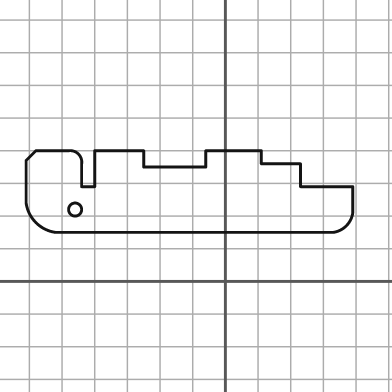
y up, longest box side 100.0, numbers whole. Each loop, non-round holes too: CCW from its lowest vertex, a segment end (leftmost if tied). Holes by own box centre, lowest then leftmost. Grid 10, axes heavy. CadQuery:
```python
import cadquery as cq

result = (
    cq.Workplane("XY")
    .moveTo(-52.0, 15.0)
    .lineTo(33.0, 15.0)
    .threePointArc((37.0, 17.0), (39.0, 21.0))
    .lineTo(39.0, 29.0)
    .lineTo(23.0, 29.0)
    .lineTo(23.0, 36.0)
    .lineTo(11.0, 36.0)
    .lineTo(11.0, 40.0)
    .lineTo(-6.0, 40.0)
    .lineTo(-6.0, 35.0)
    .lineTo(-25.0, 35.0)
    .lineTo(-25.0, 40.0)
    .lineTo(-40.0, 40.0)
    .lineTo(-40.0, 29.0)
    .lineTo(-44.0, 29.0)
    .lineTo(-44.0, 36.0)
    .threePointArc((-45.0, 39.0), (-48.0, 40.0))
    .lineTo(-58.0, 40.0)
    .lineTo(-61.0, 37.0)
    .lineTo(-61.0, 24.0)
    .threePointArc((-58.0, 18.0), (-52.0, 15.0))
    .close()
    .moveTo(-46.0, 22.0)
    .circle(2.0)
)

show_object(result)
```